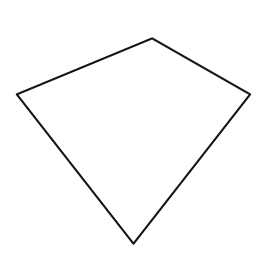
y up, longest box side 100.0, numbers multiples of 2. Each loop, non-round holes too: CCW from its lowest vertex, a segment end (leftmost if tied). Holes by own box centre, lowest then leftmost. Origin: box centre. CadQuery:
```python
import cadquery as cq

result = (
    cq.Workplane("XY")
    .moveTo(0.0, -44.0)
    .lineTo(50.0, 20.0)
    .lineTo(8.0, 44.0)
    .lineTo(-50.0, 20.0)
    .close()
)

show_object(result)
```